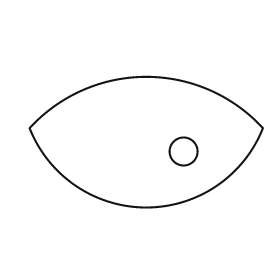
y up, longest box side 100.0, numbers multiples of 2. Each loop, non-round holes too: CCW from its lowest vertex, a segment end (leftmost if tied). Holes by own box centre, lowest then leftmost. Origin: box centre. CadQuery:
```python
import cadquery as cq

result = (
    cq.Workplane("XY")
    .moveTo(-50.0, 6.0)
    .threePointArc((0.0, -28.0), (50.0, 6.0))
    .threePointArc((0.0, 28.0), (-50.0, 6.0))
    .close()
    .moveTo(16.0, -4.0)
    .circle(6.0)
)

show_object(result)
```